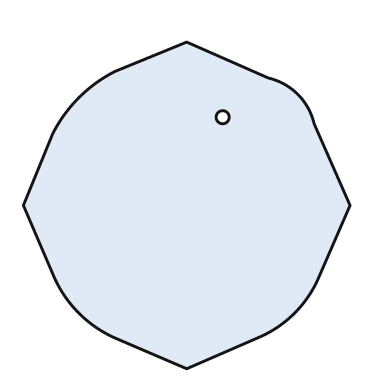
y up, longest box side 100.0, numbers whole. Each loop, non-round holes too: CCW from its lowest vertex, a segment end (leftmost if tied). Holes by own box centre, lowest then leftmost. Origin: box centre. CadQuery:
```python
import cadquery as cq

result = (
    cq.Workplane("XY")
    .moveTo(0.0, -50.0)
    .lineTo(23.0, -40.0)
    .threePointArc((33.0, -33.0), (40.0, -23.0))
    .lineTo(50.0, 0.0)
    .lineTo(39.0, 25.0)
    .threePointArc((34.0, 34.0), (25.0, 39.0))
    .lineTo(0.0, 50.0)
    .lineTo(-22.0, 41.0)
    .threePointArc((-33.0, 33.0), (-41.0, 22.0))
    .lineTo(-50.0, 0.0)
    .lineTo(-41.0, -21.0)
    .threePointArc((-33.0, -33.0), (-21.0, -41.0))
    .close()
    .moveTo(11.0, 27.0)
    .circle(2.0)
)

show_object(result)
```